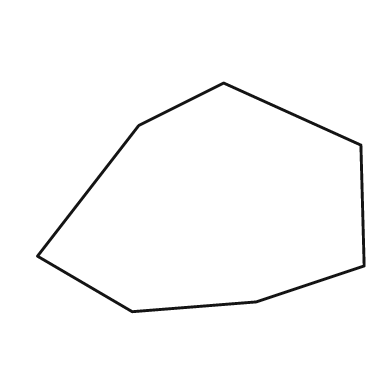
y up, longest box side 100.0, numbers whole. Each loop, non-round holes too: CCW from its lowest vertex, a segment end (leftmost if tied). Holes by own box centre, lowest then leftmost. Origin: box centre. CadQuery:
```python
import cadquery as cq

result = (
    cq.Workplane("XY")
    .moveTo(-21.0, -35.0)
    .lineTo(17.0, -32.0)
    .lineTo(50.0, -21.0)
    .lineTo(49.0, 16.0)
    .lineTo(7.0, 35.0)
    .lineTo(-19.0, 22.0)
    .lineTo(-50.0, -18.0)
    .close()
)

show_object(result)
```